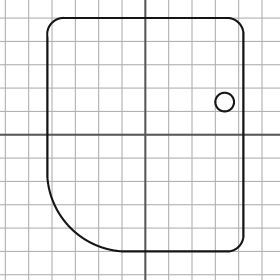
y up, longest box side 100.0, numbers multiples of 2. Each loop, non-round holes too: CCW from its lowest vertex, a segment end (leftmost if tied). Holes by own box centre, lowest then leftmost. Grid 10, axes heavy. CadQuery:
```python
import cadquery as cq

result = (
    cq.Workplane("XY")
    .moveTo(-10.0, -50.0)
    .lineTo(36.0, -50.0)
    .threePointArc((40.0, -48.0), (42.0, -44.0))
    .lineTo(42.0, 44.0)
    .threePointArc((40.0, 48.0), (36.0, 50.0))
    .lineTo(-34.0, 50.0)
    .threePointArc((-40.0, 48.0), (-42.0, 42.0))
    .lineTo(-42.0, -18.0)
    .threePointArc((-32.0, -40.0), (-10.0, -50.0))
    .close()
    .moveTo(34.0, 14.0)
    .circle(4.0)
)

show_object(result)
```